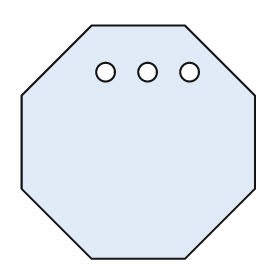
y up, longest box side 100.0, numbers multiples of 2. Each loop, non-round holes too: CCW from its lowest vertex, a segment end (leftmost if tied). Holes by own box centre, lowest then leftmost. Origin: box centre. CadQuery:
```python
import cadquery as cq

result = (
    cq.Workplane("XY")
    .moveTo(-20.0, -50.0)
    .lineTo(20.0, -50.0)
    .lineTo(50.0, -20.0)
    .lineTo(50.0, 20.0)
    .lineTo(20.0, 50.0)
    .lineTo(-20.0, 50.0)
    .lineTo(-50.0, 20.0)
    .lineTo(-50.0, -20.0)
    .close()
    .moveTo(-14.0, 30.0)
    .circle(4.0)
    .moveTo(4.0, 30.0)
    .circle(4.0)
    .moveTo(22.0, 30.0)
    .circle(4.0)
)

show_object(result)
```